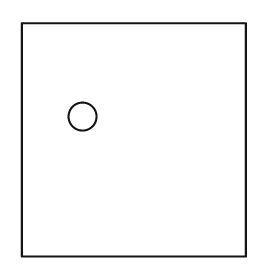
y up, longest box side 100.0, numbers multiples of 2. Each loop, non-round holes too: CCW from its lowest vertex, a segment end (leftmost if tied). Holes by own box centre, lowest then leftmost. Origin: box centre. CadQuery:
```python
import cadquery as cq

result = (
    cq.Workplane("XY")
    .moveTo(-48.0, -50.0)
    .lineTo(48.0, -50.0)
    .lineTo(48.0, 50.0)
    .lineTo(-48.0, 50.0)
    .close()
    .moveTo(-22.0, 10.0)
    .circle(6.0)
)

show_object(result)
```